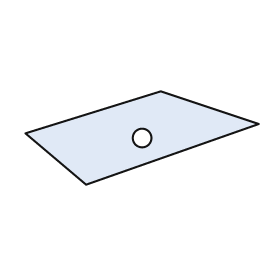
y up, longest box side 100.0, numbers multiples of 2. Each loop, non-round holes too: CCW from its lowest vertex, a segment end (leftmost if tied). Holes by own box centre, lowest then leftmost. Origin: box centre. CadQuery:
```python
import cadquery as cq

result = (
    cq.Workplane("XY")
    .moveTo(-24.0, -20.0)
    .lineTo(50.0, 6.0)
    .lineTo(8.0, 20.0)
    .lineTo(-50.0, 2.0)
    .close()
    .moveTo(0.0, 0.0)
    .circle(4.0)
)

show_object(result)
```